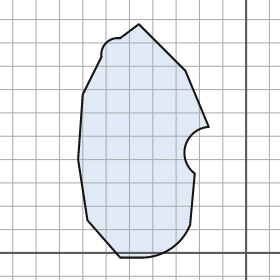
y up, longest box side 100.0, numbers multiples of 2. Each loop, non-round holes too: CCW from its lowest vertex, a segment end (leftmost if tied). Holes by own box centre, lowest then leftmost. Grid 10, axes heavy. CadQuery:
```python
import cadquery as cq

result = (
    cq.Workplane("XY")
    .moveTo(-54.0, -2.0)
    .lineTo(-44.0, -2.0)
    .threePointArc((-32.0, 2.0), (-24.0, 12.0))
    .lineTo(-22.0, 34.0)
    .threePointArc((-26.0, 46.0), (-16.0, 54.0))
    .lineTo(-26.0, 78.0)
    .lineTo(-46.0, 98.0)
    .lineTo(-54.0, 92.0)
    .threePointArc((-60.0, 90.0), (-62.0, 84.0))
    .lineTo(-70.0, 68.0)
    .lineTo(-72.0, 40.0)
    .lineTo(-68.0, 14.0)
    .close()
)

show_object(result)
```